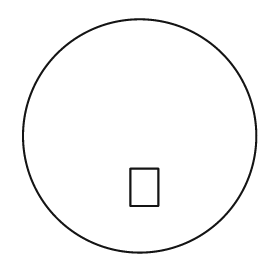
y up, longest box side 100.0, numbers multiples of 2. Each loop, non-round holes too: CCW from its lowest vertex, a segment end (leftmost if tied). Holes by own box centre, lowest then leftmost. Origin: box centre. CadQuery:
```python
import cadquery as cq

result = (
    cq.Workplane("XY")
    .moveTo(0.0, 0.0)
    .circle(50.0)
    .moveTo(-4.0, -30.0)
    .lineTo(8.0, -30.0)
    .lineTo(8.0, -14.0)
    .lineTo(-4.0, -14.0)
    .close()
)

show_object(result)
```